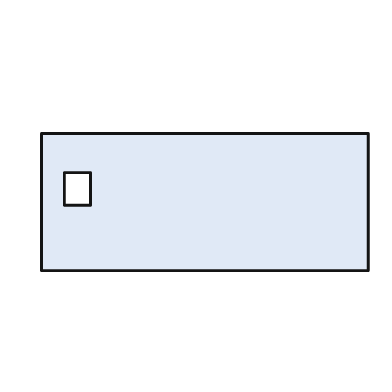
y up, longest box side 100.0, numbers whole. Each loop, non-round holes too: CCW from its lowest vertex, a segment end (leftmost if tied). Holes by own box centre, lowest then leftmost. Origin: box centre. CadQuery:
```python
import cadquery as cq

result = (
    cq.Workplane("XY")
    .moveTo(-50.0, -21.0)
    .lineTo(50.0, -21.0)
    .lineTo(50.0, 21.0)
    .lineTo(-50.0, 21.0)
    .close()
    .moveTo(-43.0, -1.0)
    .lineTo(-35.0, -1.0)
    .lineTo(-35.0, 9.0)
    .lineTo(-43.0, 9.0)
    .close()
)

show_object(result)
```